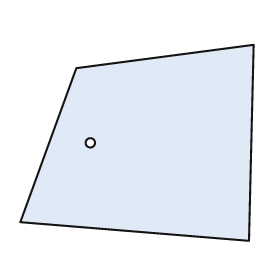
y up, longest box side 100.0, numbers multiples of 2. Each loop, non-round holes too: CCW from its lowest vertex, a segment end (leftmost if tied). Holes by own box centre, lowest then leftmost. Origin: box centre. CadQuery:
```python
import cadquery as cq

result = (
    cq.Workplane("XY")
    .moveTo(48.0, -42.0)
    .lineTo(50.0, 42.0)
    .lineTo(-26.0, 32.0)
    .lineTo(-50.0, -34.0)
    .close()
    .moveTo(-20.0, 0.0)
    .circle(2.0)
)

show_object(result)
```